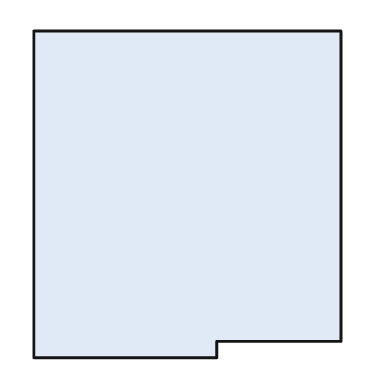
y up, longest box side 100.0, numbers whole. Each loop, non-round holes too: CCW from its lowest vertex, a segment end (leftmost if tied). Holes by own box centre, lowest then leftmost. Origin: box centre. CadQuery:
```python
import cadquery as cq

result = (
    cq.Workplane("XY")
    .moveTo(-47.0, -50.0)
    .lineTo(9.0, -50.0)
    .lineTo(9.0, -45.0)
    .lineTo(47.0, -45.0)
    .lineTo(47.0, 50.0)
    .lineTo(-47.0, 50.0)
    .close()
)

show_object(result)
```